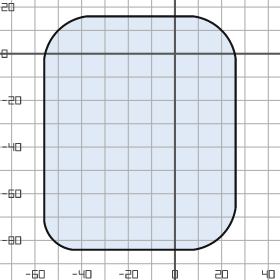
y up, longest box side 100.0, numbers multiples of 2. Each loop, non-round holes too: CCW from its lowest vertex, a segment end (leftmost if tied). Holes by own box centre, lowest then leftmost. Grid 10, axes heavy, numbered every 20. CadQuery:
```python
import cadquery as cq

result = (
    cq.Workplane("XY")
    .moveTo(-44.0, -84.0)
    .lineTo(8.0, -84.0)
    .threePointArc((20.0, -78.0), (26.0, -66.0))
    .lineTo(26.0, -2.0)
    .threePointArc((20.0, 10.0), (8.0, 16.0))
    .lineTo(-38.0, 16.0)
    .threePointArc((-50.0, 10.0), (-56.0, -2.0))
    .lineTo(-56.0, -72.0)
    .threePointArc((-52.0, -80.0), (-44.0, -84.0))
    .close()
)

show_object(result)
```